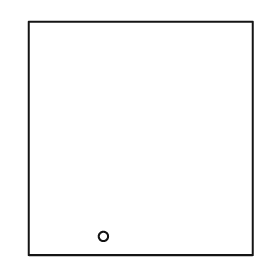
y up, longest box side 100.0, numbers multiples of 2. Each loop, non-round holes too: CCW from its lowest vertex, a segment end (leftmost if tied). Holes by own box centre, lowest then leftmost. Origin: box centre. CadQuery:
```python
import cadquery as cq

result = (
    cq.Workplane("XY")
    .moveTo(-48.0, -50.0)
    .lineTo(48.0, -50.0)
    .lineTo(48.0, 50.0)
    .lineTo(-48.0, 50.0)
    .close()
    .moveTo(-16.0, -42.0)
    .circle(2.0)
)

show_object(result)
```